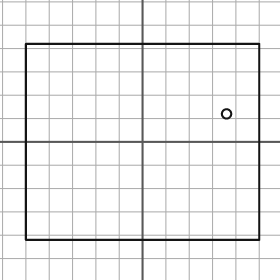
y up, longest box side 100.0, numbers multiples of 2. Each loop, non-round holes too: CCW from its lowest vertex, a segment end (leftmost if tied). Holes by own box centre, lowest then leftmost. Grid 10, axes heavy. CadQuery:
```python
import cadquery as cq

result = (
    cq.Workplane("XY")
    .moveTo(-50.0, -42.0)
    .lineTo(50.0, -42.0)
    .lineTo(50.0, 42.0)
    .lineTo(-50.0, 42.0)
    .close()
    .moveTo(36.0, 12.0)
    .circle(2.0)
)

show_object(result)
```